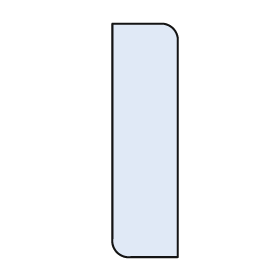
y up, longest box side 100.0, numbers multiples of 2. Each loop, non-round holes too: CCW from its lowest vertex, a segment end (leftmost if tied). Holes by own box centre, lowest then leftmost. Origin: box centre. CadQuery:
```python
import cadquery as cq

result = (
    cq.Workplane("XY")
    .moveTo(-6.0, -50.0)
    .lineTo(14.0, -50.0)
    .lineTo(14.0, 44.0)
    .threePointArc((12.0, 48.0), (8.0, 50.0))
    .lineTo(-14.0, 50.0)
    .lineTo(-14.0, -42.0)
    .threePointArc((-12.0, -48.0), (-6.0, -50.0))
    .close()
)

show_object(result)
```